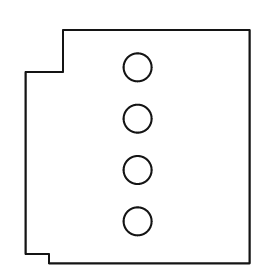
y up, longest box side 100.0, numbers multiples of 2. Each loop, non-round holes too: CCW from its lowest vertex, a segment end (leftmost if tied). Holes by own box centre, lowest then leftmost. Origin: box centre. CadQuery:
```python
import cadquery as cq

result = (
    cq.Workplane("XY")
    .moveTo(-38.0, -50.0)
    .lineTo(48.0, -50.0)
    .lineTo(48.0, 50.0)
    .lineTo(-32.0, 50.0)
    .lineTo(-32.0, 32.0)
    .lineTo(-48.0, 32.0)
    .lineTo(-48.0, -46.0)
    .lineTo(-38.0, -46.0)
    .close()
    .moveTo(0.0, -32.0)
    .circle(6.0)
    .moveTo(0.0, -10.0)
    .circle(6.0)
    .moveTo(0.0, 12.0)
    .circle(6.0)
    .moveTo(0.0, 34.0)
    .circle(6.0)
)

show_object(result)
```